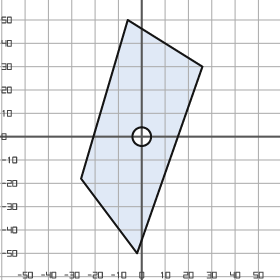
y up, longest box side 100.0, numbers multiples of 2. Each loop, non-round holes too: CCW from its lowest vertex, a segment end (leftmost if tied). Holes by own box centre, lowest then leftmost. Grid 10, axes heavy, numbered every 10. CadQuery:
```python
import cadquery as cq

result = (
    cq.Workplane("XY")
    .moveTo(-2.0, -50.0)
    .lineTo(26.0, 30.0)
    .lineTo(-6.0, 50.0)
    .lineTo(-26.0, -18.0)
    .close()
    .moveTo(0.0, 0.0)
    .circle(4.0)
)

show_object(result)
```